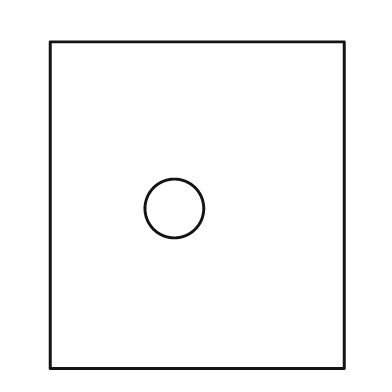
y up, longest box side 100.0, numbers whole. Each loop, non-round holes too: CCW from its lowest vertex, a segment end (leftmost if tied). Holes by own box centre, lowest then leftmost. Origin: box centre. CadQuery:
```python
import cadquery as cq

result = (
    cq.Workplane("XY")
    .moveTo(-45.0, -50.0)
    .lineTo(45.0, -50.0)
    .lineTo(45.0, 50.0)
    .lineTo(-45.0, 50.0)
    .close()
    .moveTo(-7.0, -1.0)
    .circle(9.0)
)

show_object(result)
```